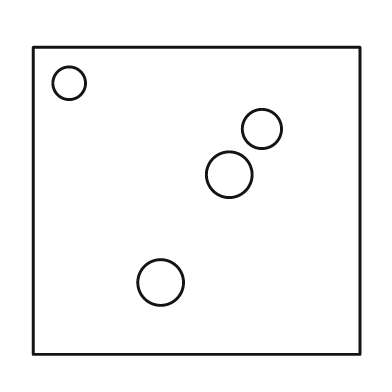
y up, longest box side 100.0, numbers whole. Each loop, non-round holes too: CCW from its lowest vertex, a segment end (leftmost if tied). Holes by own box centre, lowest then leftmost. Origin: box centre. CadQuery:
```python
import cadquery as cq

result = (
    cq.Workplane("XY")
    .moveTo(-50.0, -47.0)
    .lineTo(50.0, -47.0)
    .lineTo(50.0, 47.0)
    .lineTo(-50.0, 47.0)
    .close()
    .moveTo(-11.0, -25.0)
    .circle(7.0)
    .moveTo(10.0, 8.0)
    .circle(7.0)
    .moveTo(20.0, 22.0)
    .circle(6.0)
    .moveTo(-39.0, 36.0)
    .circle(5.0)
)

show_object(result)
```